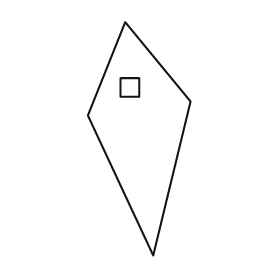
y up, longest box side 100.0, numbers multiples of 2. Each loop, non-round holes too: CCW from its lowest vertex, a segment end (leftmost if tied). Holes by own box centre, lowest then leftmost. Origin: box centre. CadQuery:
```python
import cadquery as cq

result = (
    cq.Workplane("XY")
    .moveTo(6.0, -50.0)
    .lineTo(22.0, 16.0)
    .lineTo(-6.0, 50.0)
    .lineTo(-22.0, 10.0)
    .close()
    .moveTo(-8.0, 18.0)
    .lineTo(0.0, 18.0)
    .lineTo(0.0, 26.0)
    .lineTo(-8.0, 26.0)
    .close()
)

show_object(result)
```